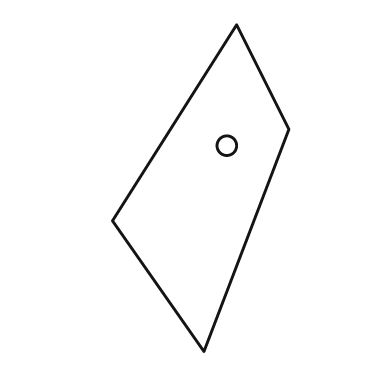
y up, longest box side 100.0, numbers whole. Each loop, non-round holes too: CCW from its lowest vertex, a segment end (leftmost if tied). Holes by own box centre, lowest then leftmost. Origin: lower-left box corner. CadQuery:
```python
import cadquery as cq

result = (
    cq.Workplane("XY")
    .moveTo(28.0, 0.0)
    .lineTo(54.0, 68.0)
    .lineTo(38.0, 100.0)
    .lineTo(0.0, 40.0)
    .close()
    .moveTo(35.0, 63.0)
    .circle(3.0)
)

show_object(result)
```